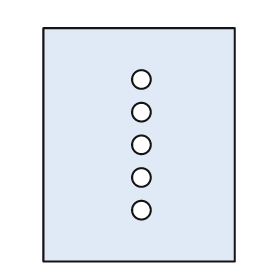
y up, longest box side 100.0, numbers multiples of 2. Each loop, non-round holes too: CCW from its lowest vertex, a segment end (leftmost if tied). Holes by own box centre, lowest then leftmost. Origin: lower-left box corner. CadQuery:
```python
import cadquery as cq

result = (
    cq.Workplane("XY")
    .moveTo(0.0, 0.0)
    .lineTo(82.0, 0.0)
    .lineTo(82.0, 100.0)
    .lineTo(0.0, 100.0)
    .close()
    .moveTo(42.0, 22.0)
    .circle(4.0)
    .moveTo(42.0, 36.0)
    .circle(4.0)
    .moveTo(42.0, 50.0)
    .circle(4.0)
    .moveTo(42.0, 64.0)
    .circle(4.0)
    .moveTo(42.0, 78.0)
    .circle(4.0)
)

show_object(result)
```